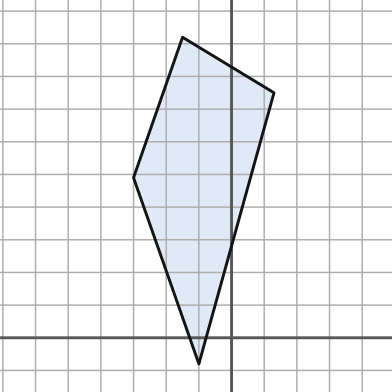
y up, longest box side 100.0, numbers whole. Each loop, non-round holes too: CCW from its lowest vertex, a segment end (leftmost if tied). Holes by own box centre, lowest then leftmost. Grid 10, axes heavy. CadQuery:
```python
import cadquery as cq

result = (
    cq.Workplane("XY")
    .moveTo(-10.0, -8.0)
    .lineTo(13.0, 75.0)
    .lineTo(-15.0, 92.0)
    .lineTo(-30.0, 49.0)
    .close()
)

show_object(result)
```